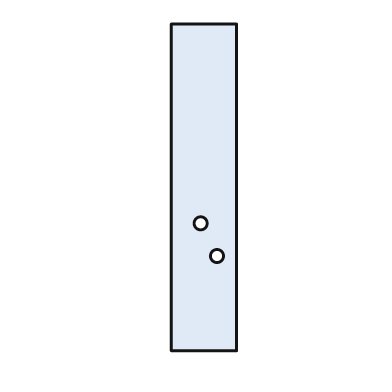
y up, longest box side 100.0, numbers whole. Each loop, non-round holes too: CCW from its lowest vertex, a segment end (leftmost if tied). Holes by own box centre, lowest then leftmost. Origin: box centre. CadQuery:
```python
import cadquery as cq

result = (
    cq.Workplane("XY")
    .moveTo(-10.0, -50.0)
    .lineTo(10.0, -50.0)
    .lineTo(10.0, 50.0)
    .lineTo(-10.0, 50.0)
    .close()
    .moveTo(4.0, -21.0)
    .circle(2.0)
    .moveTo(-1.0, -11.0)
    .circle(2.0)
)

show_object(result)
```